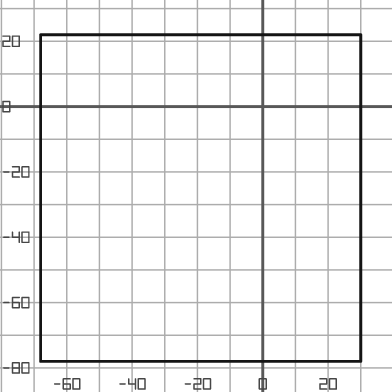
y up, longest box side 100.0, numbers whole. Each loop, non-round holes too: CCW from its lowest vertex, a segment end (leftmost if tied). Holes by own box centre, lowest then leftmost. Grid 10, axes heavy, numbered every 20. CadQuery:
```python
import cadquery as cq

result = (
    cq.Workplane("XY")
    .moveTo(-68.0, -78.0)
    .lineTo(30.0, -78.0)
    .lineTo(30.0, 22.0)
    .lineTo(-68.0, 22.0)
    .close()
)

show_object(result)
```